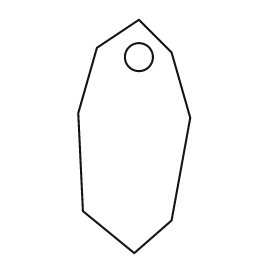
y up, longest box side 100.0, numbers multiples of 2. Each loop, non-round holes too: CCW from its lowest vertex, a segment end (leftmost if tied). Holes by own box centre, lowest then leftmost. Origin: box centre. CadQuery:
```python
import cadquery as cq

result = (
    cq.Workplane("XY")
    .moveTo(0.0, -50.0)
    .lineTo(16.0, -36.0)
    .lineTo(24.0, 8.0)
    .lineTo(16.0, 36.0)
    .lineTo(2.0, 50.0)
    .lineTo(-16.0, 38.0)
    .lineTo(-24.0, 10.0)
    .lineTo(-22.0, -32.0)
    .close()
    .moveTo(2.0, 34.0)
    .circle(6.0)
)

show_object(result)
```